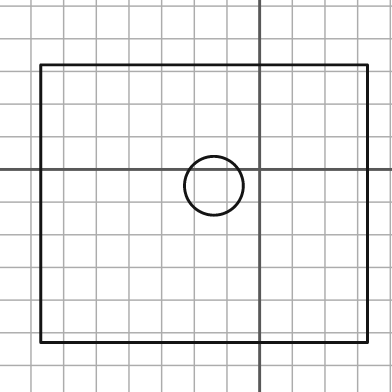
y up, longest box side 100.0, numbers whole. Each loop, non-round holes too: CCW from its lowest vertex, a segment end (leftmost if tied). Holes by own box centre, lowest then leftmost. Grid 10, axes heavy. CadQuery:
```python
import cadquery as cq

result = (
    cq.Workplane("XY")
    .moveTo(-67.0, -53.0)
    .lineTo(33.0, -53.0)
    .lineTo(33.0, 32.0)
    .lineTo(-67.0, 32.0)
    .close()
    .moveTo(-14.0, -5.0)
    .circle(9.0)
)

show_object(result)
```